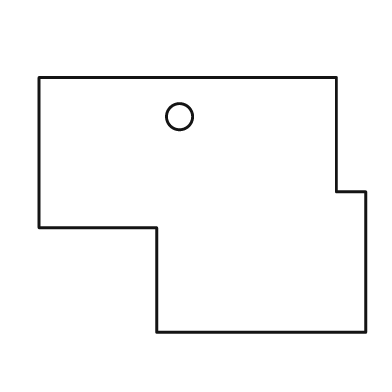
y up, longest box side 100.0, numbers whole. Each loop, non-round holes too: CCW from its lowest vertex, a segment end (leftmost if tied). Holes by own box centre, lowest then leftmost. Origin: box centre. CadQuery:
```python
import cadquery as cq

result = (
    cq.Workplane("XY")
    .moveTo(-14.0, -39.0)
    .lineTo(50.0, -39.0)
    .lineTo(50.0, 4.0)
    .lineTo(41.0, 4.0)
    .lineTo(41.0, 39.0)
    .lineTo(-50.0, 39.0)
    .lineTo(-50.0, -7.0)
    .lineTo(-14.0, -7.0)
    .close()
    .moveTo(-7.0, 27.0)
    .circle(4.0)
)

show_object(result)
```